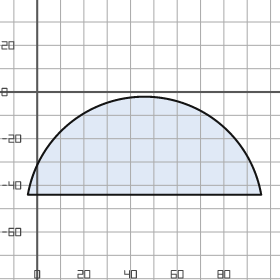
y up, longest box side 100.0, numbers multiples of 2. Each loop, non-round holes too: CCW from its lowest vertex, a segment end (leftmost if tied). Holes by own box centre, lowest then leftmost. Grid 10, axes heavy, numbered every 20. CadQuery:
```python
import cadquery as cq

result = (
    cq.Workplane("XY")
    .moveTo(-4.0, -44.0)
    .lineTo(96.0, -44.0)
    .threePointArc((46.0, -2.0), (-4.0, -44.0))
    .close()
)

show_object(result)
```